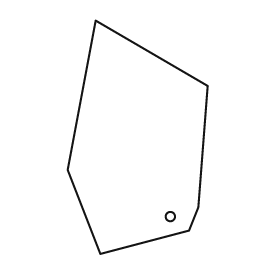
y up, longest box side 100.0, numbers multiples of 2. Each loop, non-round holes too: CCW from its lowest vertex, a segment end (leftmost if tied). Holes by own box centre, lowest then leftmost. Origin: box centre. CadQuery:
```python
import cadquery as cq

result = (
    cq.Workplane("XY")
    .moveTo(-16.0, -50.0)
    .lineTo(22.0, -40.0)
    .lineTo(26.0, -30.0)
    .lineTo(30.0, 22.0)
    .lineTo(-18.0, 50.0)
    .lineTo(-30.0, -14.0)
    .close()
    .moveTo(14.0, -34.0)
    .circle(2.0)
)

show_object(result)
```